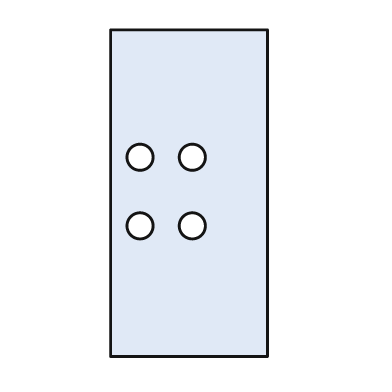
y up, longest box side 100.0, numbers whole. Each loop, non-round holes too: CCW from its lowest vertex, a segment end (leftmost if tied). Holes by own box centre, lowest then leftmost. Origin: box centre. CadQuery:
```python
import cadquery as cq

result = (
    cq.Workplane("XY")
    .moveTo(-24.0, -50.0)
    .lineTo(24.0, -50.0)
    .lineTo(24.0, 50.0)
    .lineTo(-24.0, 50.0)
    .close()
    .moveTo(-15.0, -10.0)
    .circle(4.0)
    .moveTo(1.0, -10.0)
    .circle(4.0)
    .moveTo(-15.0, 11.0)
    .circle(4.0)
    .moveTo(1.0, 11.0)
    .circle(4.0)
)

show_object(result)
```